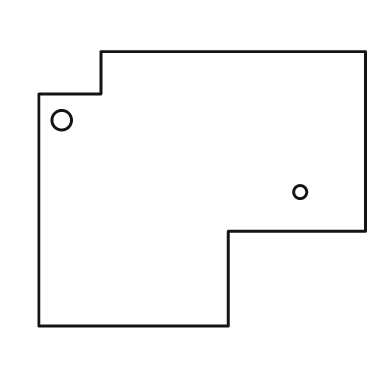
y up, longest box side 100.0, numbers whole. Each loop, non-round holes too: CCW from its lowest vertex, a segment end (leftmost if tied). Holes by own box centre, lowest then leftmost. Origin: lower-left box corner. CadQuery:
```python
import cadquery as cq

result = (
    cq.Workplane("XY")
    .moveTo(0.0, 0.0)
    .lineTo(58.0, 0.0)
    .lineTo(58.0, 29.0)
    .lineTo(100.0, 29.0)
    .lineTo(100.0, 84.0)
    .lineTo(19.0, 84.0)
    .lineTo(19.0, 71.0)
    .lineTo(0.0, 71.0)
    .close()
    .moveTo(80.0, 41.0)
    .circle(2.0)
    .moveTo(7.0, 63.0)
    .circle(3.0)
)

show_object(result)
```